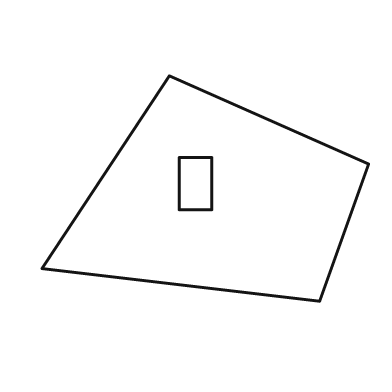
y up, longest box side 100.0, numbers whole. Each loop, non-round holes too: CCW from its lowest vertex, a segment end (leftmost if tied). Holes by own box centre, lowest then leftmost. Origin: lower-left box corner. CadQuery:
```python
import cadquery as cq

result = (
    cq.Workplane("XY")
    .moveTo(85.0, 0.0)
    .lineTo(100.0, 42.0)
    .lineTo(39.0, 69.0)
    .lineTo(0.0, 10.0)
    .close()
    .moveTo(42.0, 28.0)
    .lineTo(52.0, 28.0)
    .lineTo(52.0, 44.0)
    .lineTo(42.0, 44.0)
    .close()
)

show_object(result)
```